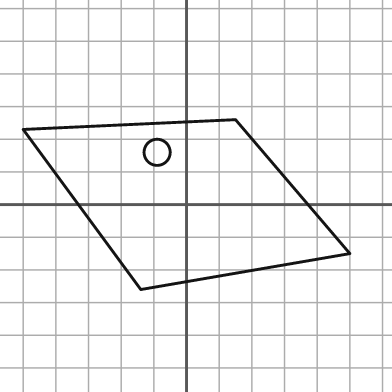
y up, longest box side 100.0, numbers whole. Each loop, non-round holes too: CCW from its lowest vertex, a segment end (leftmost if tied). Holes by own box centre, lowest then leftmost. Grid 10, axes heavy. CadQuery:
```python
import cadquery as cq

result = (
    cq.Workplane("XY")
    .moveTo(-14.0, -26.0)
    .lineTo(50.0, -15.0)
    .lineTo(15.0, 26.0)
    .lineTo(-50.0, 23.0)
    .close()
    .moveTo(-9.0, 16.0)
    .circle(4.0)
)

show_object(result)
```